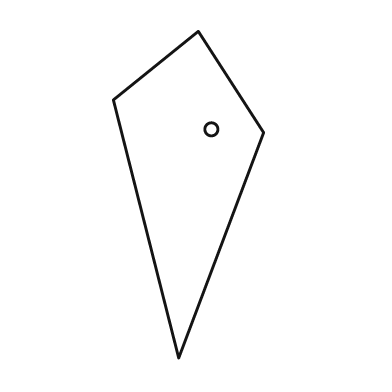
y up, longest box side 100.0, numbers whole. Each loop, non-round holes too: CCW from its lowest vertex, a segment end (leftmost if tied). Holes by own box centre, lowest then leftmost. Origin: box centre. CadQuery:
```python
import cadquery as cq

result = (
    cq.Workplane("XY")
    .moveTo(-3.0, -50.0)
    .lineTo(23.0, 19.0)
    .lineTo(3.0, 50.0)
    .lineTo(-23.0, 29.0)
    .close()
    .moveTo(7.0, 20.0)
    .circle(2.0)
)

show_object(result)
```